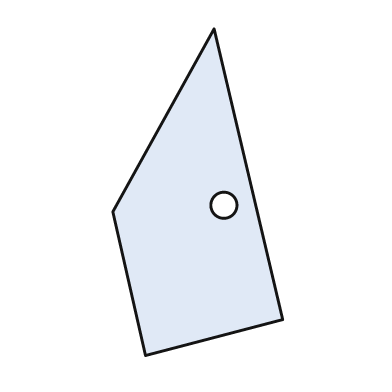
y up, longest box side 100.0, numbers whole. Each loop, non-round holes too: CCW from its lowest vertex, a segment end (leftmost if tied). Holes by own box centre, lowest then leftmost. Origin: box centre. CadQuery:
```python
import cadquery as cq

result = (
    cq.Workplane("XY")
    .moveTo(-16.0, -50.0)
    .lineTo(26.0, -39.0)
    .lineTo(5.0, 50.0)
    .lineTo(-26.0, -6.0)
    .close()
    .moveTo(8.0, -4.0)
    .circle(4.0)
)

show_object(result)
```